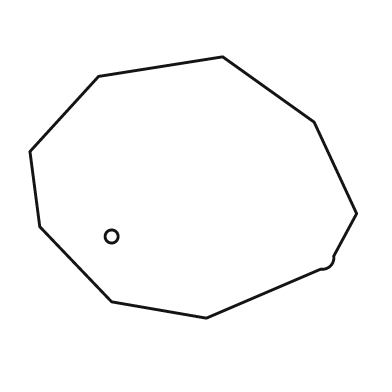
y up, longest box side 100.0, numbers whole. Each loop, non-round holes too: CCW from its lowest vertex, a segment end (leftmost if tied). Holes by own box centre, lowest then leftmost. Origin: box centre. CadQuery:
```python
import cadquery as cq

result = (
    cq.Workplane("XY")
    .moveTo(4.0, -40.0)
    .lineTo(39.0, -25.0)
    .threePointArc((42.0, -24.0), (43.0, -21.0))
    .lineTo(50.0, -8.0)
    .lineTo(37.0, 20.0)
    .lineTo(9.0, 40.0)
    .lineTo(-29.0, 34.0)
    .lineTo(-50.0, 11.0)
    .lineTo(-47.0, -12.0)
    .lineTo(-25.0, -35.0)
    .close()
    .moveTo(-25.0, -15.0)
    .circle(2.0)
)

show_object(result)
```